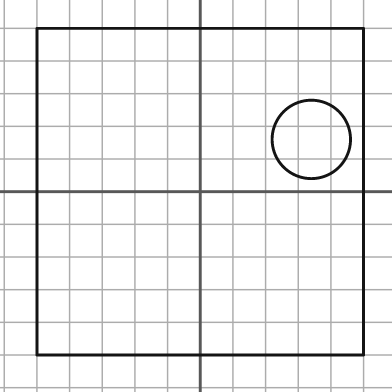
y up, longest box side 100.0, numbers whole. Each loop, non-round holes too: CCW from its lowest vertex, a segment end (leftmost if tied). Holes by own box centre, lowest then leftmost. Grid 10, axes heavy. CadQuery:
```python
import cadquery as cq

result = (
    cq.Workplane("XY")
    .moveTo(-50.0, -50.0)
    .lineTo(50.0, -50.0)
    .lineTo(50.0, 50.0)
    .lineTo(-50.0, 50.0)
    .close()
    .moveTo(34.0, 16.0)
    .circle(12.0)
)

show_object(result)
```